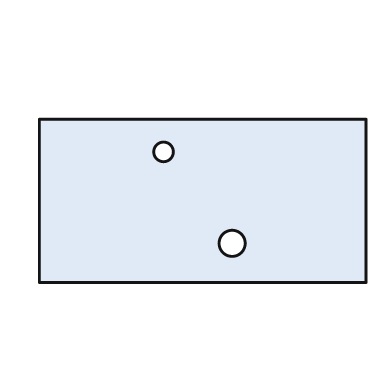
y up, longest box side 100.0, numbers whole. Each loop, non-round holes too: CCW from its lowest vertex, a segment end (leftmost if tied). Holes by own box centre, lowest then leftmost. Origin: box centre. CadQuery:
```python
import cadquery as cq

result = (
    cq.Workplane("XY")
    .moveTo(-50.0, -25.0)
    .lineTo(50.0, -25.0)
    .lineTo(50.0, 25.0)
    .lineTo(-50.0, 25.0)
    .close()
    .moveTo(9.0, -13.0)
    .circle(4.0)
    .moveTo(-12.0, 15.0)
    .circle(3.0)
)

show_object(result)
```